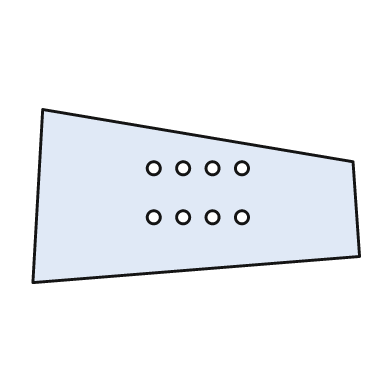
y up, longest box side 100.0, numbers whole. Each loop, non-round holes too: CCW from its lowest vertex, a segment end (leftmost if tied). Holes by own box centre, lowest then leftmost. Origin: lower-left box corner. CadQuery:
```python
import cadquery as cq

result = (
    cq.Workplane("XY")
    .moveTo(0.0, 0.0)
    .lineTo(100.0, 8.0)
    .lineTo(98.0, 37.0)
    .lineTo(3.0, 53.0)
    .close()
    .moveTo(37.0, 20.0)
    .circle(2.0)
    .moveTo(46.0, 20.0)
    .circle(2.0)
    .moveTo(55.0, 20.0)
    .circle(2.0)
    .moveTo(64.0, 20.0)
    .circle(2.0)
    .moveTo(37.0, 35.0)
    .circle(2.0)
    .moveTo(46.0, 35.0)
    .circle(2.0)
    .moveTo(55.0, 35.0)
    .circle(2.0)
    .moveTo(64.0, 35.0)
    .circle(2.0)
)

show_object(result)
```